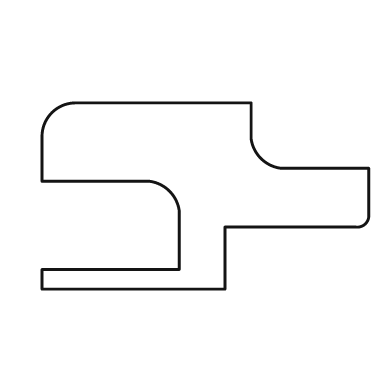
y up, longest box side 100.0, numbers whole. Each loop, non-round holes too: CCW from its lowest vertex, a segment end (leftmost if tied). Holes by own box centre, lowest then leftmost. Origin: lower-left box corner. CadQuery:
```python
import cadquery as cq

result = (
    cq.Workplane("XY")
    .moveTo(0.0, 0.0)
    .lineTo(56.0, 0.0)
    .lineTo(56.0, 19.0)
    .lineTo(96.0, 19.0)
    .threePointArc((99.0, 20.0), (100.0, 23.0))
    .lineTo(100.0, 37.0)
    .lineTo(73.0, 37.0)
    .threePointArc((67.0, 40.0), (64.0, 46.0))
    .lineTo(64.0, 57.0)
    .lineTo(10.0, 57.0)
    .threePointArc((3.0, 54.0), (0.0, 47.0))
    .lineTo(0.0, 33.0)
    .lineTo(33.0, 33.0)
    .threePointArc((39.0, 30.0), (42.0, 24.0))
    .lineTo(42.0, 6.0)
    .lineTo(0.0, 6.0)
    .close()
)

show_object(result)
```